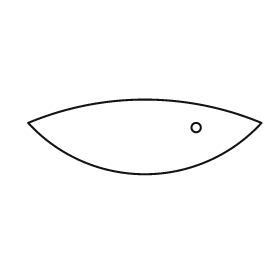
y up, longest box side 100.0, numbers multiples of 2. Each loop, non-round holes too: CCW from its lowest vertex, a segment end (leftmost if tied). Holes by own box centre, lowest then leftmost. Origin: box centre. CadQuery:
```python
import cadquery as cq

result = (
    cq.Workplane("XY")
    .moveTo(-50.0, 6.0)
    .threePointArc((0.0, -16.0), (50.0, 6.0))
    .threePointArc((0.0, 16.0), (-50.0, 6.0))
    .close()
    .moveTo(22.0, 4.0)
    .circle(2.0)
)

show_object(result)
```